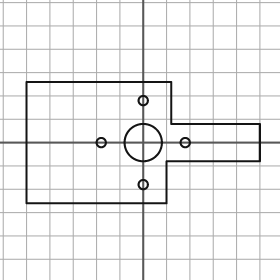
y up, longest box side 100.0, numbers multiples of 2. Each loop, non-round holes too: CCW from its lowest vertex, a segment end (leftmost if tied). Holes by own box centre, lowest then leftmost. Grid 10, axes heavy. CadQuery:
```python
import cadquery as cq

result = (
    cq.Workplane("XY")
    .moveTo(-50.0, -26.0)
    .lineTo(10.0, -26.0)
    .lineTo(10.0, -8.0)
    .lineTo(50.0, -8.0)
    .lineTo(50.0, 8.0)
    .lineTo(12.0, 8.0)
    .lineTo(12.0, 26.0)
    .lineTo(-50.0, 26.0)
    .close()
    .moveTo(0.0, -18.0)
    .circle(2.0)
    .moveTo(-18.0, 0.0)
    .circle(2.0)
    .moveTo(0.0, 0.0)
    .circle(8.0)
    .moveTo(18.0, 0.0)
    .circle(2.0)
    .moveTo(0.0, 18.0)
    .circle(2.0)
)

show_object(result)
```